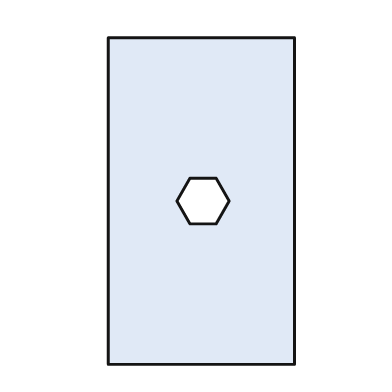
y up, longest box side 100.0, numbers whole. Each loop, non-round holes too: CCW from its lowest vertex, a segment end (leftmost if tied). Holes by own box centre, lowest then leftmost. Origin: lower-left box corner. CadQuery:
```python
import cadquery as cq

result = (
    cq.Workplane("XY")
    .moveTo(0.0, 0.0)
    .lineTo(57.0, 0.0)
    .lineTo(57.0, 100.0)
    .lineTo(0.0, 100.0)
    .close()
    .moveTo(25.0, 43.0)
    .lineTo(33.0, 43.0)
    .lineTo(37.0, 50.0)
    .lineTo(33.0, 57.0)
    .lineTo(25.0, 57.0)
    .lineTo(21.0, 50.0)
    .close()
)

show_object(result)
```